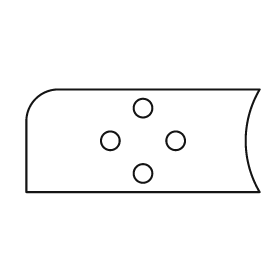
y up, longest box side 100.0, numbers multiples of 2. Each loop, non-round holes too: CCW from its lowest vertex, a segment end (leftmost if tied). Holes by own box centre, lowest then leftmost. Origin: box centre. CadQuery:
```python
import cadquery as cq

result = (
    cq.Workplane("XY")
    .moveTo(-50.0, -22.0)
    .lineTo(50.0, -22.0)
    .threePointArc((44.0, 0.0), (50.0, 22.0))
    .lineTo(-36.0, 22.0)
    .threePointArc((-46.0, 18.0), (-50.0, 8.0))
    .close()
    .moveTo(0.0, -14.0)
    .circle(4.0)
    .moveTo(-14.0, 0.0)
    .circle(4.0)
    .moveTo(14.0, 0.0)
    .circle(4.0)
    .moveTo(0.0, 14.0)
    .circle(4.0)
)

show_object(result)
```